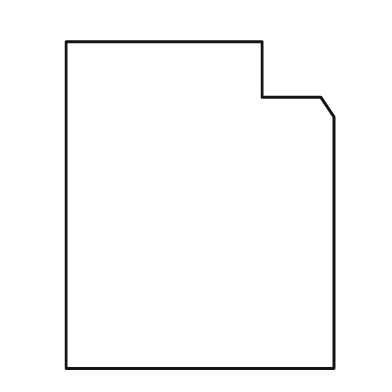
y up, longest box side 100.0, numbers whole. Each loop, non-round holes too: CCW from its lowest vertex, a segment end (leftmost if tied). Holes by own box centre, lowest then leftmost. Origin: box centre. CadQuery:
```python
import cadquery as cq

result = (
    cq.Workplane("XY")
    .moveTo(-41.0, -50.0)
    .lineTo(41.0, -50.0)
    .lineTo(41.0, 27.0)
    .lineTo(37.0, 33.0)
    .lineTo(19.0, 33.0)
    .lineTo(19.0, 50.0)
    .lineTo(-41.0, 50.0)
    .close()
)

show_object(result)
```